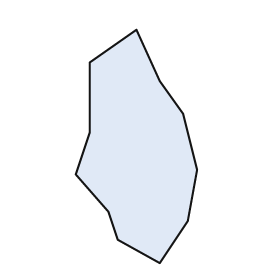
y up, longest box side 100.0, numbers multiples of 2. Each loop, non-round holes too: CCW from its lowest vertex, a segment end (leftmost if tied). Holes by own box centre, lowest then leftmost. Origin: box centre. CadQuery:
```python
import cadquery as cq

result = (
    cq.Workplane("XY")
    .moveTo(10.0, -50.0)
    .lineTo(22.0, -32.0)
    .lineTo(26.0, -10.0)
    .lineTo(20.0, 14.0)
    .lineTo(10.0, 28.0)
    .lineTo(0.0, 50.0)
    .lineTo(-20.0, 36.0)
    .lineTo(-20.0, 6.0)
    .lineTo(-26.0, -12.0)
    .lineTo(-12.0, -28.0)
    .lineTo(-8.0, -40.0)
    .close()
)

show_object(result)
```